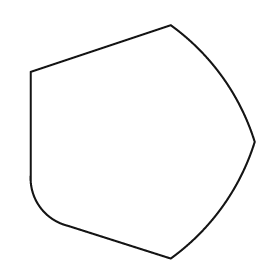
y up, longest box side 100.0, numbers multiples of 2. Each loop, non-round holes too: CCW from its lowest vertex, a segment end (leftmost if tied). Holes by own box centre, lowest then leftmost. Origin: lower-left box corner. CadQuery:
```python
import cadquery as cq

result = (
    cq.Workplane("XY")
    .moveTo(60.0, 0.0)
    .threePointArc((82.0, 22.0), (96.0, 50.0))
    .threePointArc((82.0, 78.0), (60.0, 100.0))
    .lineTo(0.0, 80.0)
    .lineTo(0.0, 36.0)
    .threePointArc((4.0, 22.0), (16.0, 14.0))
    .close()
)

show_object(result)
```